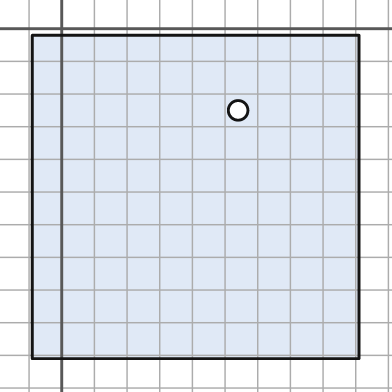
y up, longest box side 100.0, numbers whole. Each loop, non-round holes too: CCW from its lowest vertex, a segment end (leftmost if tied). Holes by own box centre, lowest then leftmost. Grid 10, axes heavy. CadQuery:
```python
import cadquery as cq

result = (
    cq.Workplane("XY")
    .moveTo(-9.0, -101.0)
    .lineTo(91.0, -101.0)
    .lineTo(91.0, -2.0)
    .lineTo(-9.0, -2.0)
    .close()
    .moveTo(54.0, -25.0)
    .circle(3.0)
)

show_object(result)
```